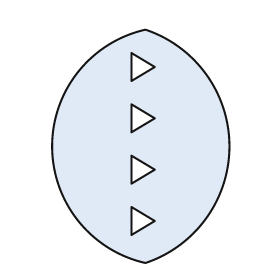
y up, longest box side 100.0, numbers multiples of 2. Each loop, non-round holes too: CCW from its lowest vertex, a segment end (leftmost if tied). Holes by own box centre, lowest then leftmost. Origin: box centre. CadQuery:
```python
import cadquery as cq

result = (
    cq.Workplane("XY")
    .moveTo(2.0, -50.0)
    .threePointArc((38.0, 0.0), (2.0, 50.0))
    .threePointArc((-38.0, 0.0), (2.0, -50.0))
    .close()
    .moveTo(-4.0, -38.0)
    .lineTo(6.0, -32.0)
    .lineTo(-4.0, -26.0)
    .close()
    .moveTo(-4.0, -16.0)
    .lineTo(6.0, -10.0)
    .lineTo(-4.0, -4.0)
    .close()
    .moveTo(-4.0, 6.0)
    .lineTo(6.0, 12.0)
    .lineTo(-4.0, 18.0)
    .close()
    .moveTo(-4.0, 28.0)
    .lineTo(6.0, 34.0)
    .lineTo(-4.0, 40.0)
    .close()
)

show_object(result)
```